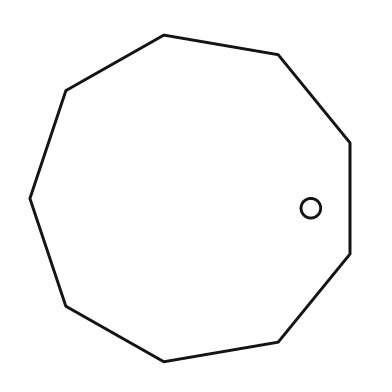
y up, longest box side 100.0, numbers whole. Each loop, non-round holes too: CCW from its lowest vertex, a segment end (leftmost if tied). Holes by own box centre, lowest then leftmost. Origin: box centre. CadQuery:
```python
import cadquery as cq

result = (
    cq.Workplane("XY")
    .moveTo(-8.0, -50.0)
    .lineTo(27.0, -44.0)
    .lineTo(49.0, -17.0)
    .lineTo(49.0, 17.0)
    .lineTo(27.0, 44.0)
    .lineTo(-8.0, 50.0)
    .lineTo(-38.0, 33.0)
    .lineTo(-49.0, 0.0)
    .lineTo(-38.0, -33.0)
    .close()
    .moveTo(37.0, -3.0)
    .circle(3.0)
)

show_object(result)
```